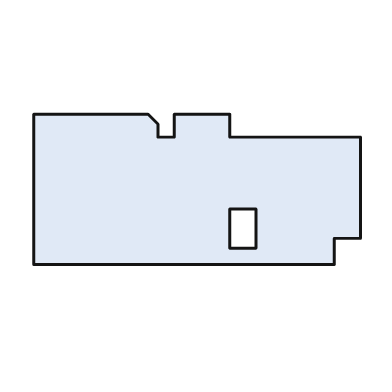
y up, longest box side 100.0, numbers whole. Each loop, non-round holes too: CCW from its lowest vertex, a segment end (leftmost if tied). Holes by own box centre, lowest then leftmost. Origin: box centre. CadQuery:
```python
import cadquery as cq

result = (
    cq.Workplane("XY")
    .moveTo(-50.0, -23.0)
    .lineTo(42.0, -23.0)
    .lineTo(42.0, -15.0)
    .lineTo(50.0, -15.0)
    .lineTo(50.0, 16.0)
    .lineTo(10.0, 16.0)
    .lineTo(10.0, 23.0)
    .lineTo(-7.0, 23.0)
    .lineTo(-7.0, 16.0)
    .lineTo(-12.0, 16.0)
    .lineTo(-12.0, 20.0)
    .lineTo(-15.0, 23.0)
    .lineTo(-50.0, 23.0)
    .close()
    .moveTo(10.0, -18.0)
    .lineTo(18.0, -18.0)
    .lineTo(18.0, -6.0)
    .lineTo(10.0, -6.0)
    .close()
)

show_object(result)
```